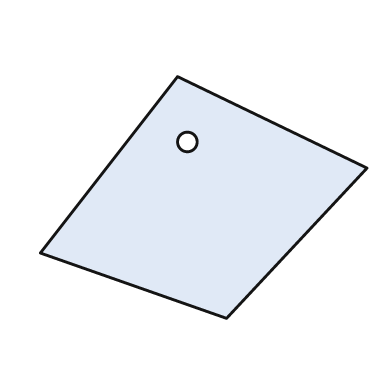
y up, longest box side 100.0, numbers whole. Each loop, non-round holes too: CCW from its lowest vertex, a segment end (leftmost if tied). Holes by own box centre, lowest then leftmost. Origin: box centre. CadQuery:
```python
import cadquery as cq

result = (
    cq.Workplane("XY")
    .moveTo(7.0, -37.0)
    .lineTo(50.0, 9.0)
    .lineTo(-8.0, 37.0)
    .lineTo(-50.0, -17.0)
    .close()
    .moveTo(-5.0, 17.0)
    .circle(3.0)
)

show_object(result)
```